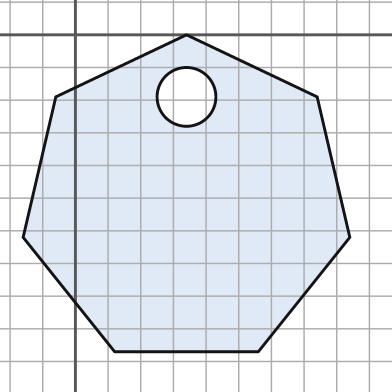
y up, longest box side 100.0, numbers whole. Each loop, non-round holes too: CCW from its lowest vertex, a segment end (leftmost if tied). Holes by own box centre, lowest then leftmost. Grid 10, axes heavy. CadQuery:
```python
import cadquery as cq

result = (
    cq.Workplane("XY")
    .moveTo(12.0, -97.0)
    .lineTo(56.0, -97.0)
    .lineTo(84.0, -62.0)
    .lineTo(74.0, -19.0)
    .lineTo(34.0, 0.0)
    .lineTo(-6.0, -19.0)
    .lineTo(-16.0, -62.0)
    .close()
    .moveTo(34.0, -19.0)
    .circle(9.0)
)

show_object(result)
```